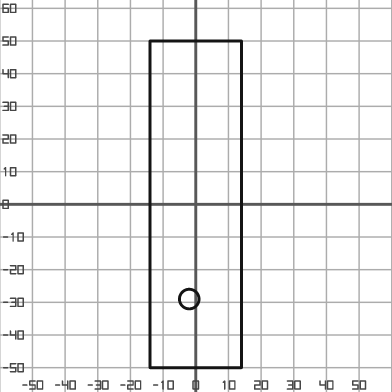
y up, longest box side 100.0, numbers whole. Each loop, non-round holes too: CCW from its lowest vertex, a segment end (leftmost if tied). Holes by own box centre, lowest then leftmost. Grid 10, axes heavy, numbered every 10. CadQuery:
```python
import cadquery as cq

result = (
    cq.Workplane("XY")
    .moveTo(-14.0, -50.0)
    .lineTo(14.0, -50.0)
    .lineTo(14.0, 50.0)
    .lineTo(-14.0, 50.0)
    .close()
    .moveTo(-2.0, -29.0)
    .circle(3.0)
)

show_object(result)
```